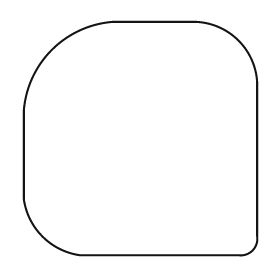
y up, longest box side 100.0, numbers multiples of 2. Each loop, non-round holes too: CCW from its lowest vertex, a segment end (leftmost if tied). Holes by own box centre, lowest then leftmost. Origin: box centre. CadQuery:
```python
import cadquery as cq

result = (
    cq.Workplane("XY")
    .moveTo(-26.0, -50.0)
    .lineTo(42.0, -50.0)
    .threePointArc((48.0, -48.0), (50.0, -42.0))
    .lineTo(50.0, 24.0)
    .threePointArc((42.0, 42.0), (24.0, 50.0))
    .lineTo(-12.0, 50.0)
    .threePointArc((-38.0, 38.0), (-50.0, 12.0))
    .lineTo(-50.0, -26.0)
    .threePointArc((-42.0, -42.0), (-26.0, -50.0))
    .close()
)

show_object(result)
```